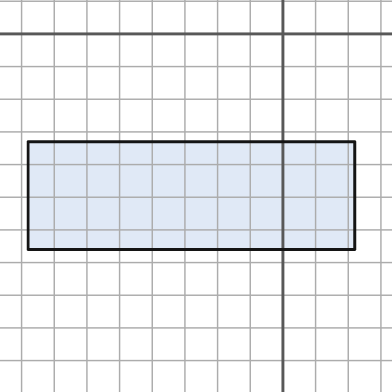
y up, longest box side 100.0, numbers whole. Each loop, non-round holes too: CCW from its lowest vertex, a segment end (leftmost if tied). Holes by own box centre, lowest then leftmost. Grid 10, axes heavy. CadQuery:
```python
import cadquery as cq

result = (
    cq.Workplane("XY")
    .moveTo(-78.0, -66.0)
    .lineTo(22.0, -66.0)
    .lineTo(22.0, -33.0)
    .lineTo(-78.0, -33.0)
    .close()
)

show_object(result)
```